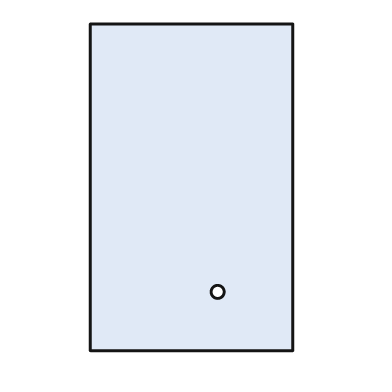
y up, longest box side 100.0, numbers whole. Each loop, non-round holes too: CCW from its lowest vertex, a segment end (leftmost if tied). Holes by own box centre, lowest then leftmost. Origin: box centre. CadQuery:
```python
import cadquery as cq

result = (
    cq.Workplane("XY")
    .moveTo(-31.0, -50.0)
    .lineTo(31.0, -50.0)
    .lineTo(31.0, 50.0)
    .lineTo(-31.0, 50.0)
    .close()
    .moveTo(8.0, -32.0)
    .circle(2.0)
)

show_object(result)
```